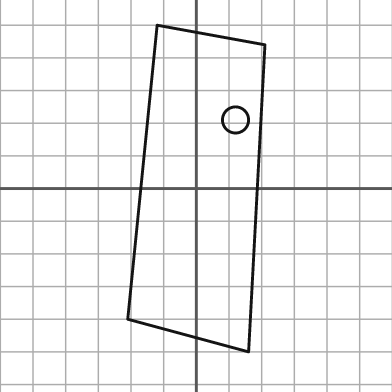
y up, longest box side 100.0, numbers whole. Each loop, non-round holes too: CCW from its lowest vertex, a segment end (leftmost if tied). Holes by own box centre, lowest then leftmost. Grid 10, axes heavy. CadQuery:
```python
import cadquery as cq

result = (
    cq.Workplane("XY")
    .moveTo(16.0, -50.0)
    .lineTo(21.0, 44.0)
    .lineTo(-12.0, 50.0)
    .lineTo(-21.0, -40.0)
    .close()
    .moveTo(12.0, 21.0)
    .circle(4.0)
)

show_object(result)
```